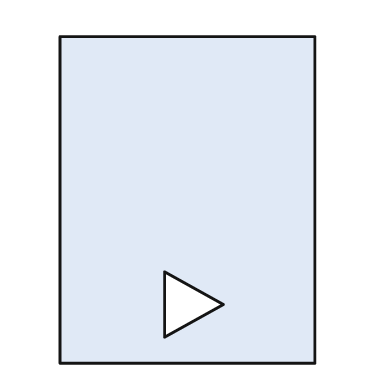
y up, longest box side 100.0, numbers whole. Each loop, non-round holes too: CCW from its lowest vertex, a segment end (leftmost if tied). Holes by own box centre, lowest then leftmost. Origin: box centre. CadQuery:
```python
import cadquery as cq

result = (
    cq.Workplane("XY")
    .moveTo(-39.0, -50.0)
    .lineTo(39.0, -50.0)
    .lineTo(39.0, 50.0)
    .lineTo(-39.0, 50.0)
    .close()
    .moveTo(-7.0, -42.0)
    .lineTo(11.0, -32.0)
    .lineTo(-7.0, -22.0)
    .close()
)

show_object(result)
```